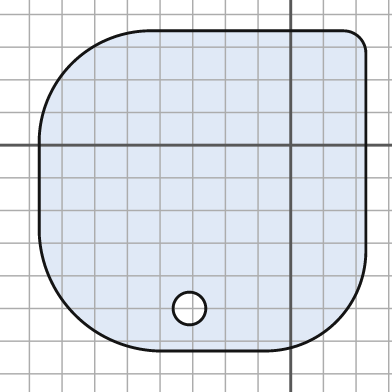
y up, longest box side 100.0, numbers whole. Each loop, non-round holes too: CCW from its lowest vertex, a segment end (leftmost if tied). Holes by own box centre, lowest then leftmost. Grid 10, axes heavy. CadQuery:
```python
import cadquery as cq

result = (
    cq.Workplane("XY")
    .moveTo(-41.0, -63.0)
    .lineTo(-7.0, -63.0)
    .threePointArc((14.0, -54.0), (23.0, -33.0))
    .lineTo(23.0, 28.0)
    .threePointArc((21.0, 33.0), (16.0, 35.0))
    .lineTo(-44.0, 35.0)
    .threePointArc((-67.0, 25.0), (-77.0, 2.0))
    .lineTo(-77.0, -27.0)
    .threePointArc((-66.0, -52.0), (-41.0, -63.0))
    .close()
    .moveTo(-31.0, -50.0)
    .circle(5.0)
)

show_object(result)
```